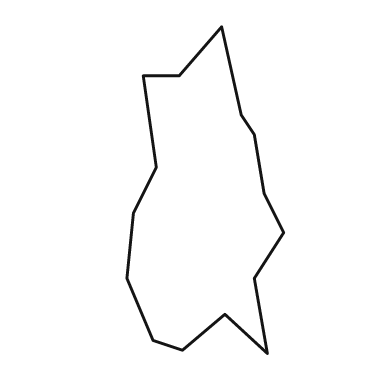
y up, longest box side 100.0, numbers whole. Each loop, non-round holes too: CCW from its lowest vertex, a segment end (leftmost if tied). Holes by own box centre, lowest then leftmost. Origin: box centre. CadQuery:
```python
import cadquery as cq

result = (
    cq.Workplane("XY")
    .moveTo(19.0, -50.0)
    .lineTo(15.0, -27.0)
    .lineTo(24.0, -13.0)
    .lineTo(18.0, -1.0)
    .lineTo(15.0, 17.0)
    .lineTo(11.0, 23.0)
    .lineTo(5.0, 50.0)
    .lineTo(-8.0, 35.0)
    .lineTo(-19.0, 35.0)
    .lineTo(-15.0, 7.0)
    .lineTo(-22.0, -7.0)
    .lineTo(-24.0, -27.0)
    .lineTo(-16.0, -46.0)
    .lineTo(-7.0, -49.0)
    .lineTo(6.0, -38.0)
    .close()
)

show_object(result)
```